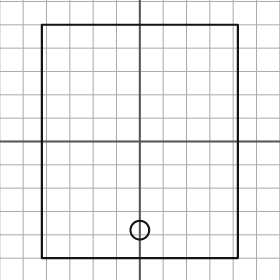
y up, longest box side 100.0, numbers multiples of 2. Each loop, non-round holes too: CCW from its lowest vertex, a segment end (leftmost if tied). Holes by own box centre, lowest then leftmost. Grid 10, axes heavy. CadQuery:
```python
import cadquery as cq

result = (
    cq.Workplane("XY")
    .moveTo(-42.0, -50.0)
    .lineTo(42.0, -50.0)
    .lineTo(42.0, 50.0)
    .lineTo(-42.0, 50.0)
    .close()
    .moveTo(0.0, -38.0)
    .circle(4.0)
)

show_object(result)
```